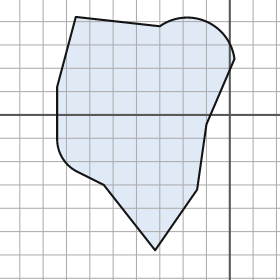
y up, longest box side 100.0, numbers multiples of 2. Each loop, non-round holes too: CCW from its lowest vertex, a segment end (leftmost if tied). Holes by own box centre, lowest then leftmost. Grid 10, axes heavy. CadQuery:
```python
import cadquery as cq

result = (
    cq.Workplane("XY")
    .moveTo(-32.0, -58.0)
    .lineTo(-14.0, -32.0)
    .lineTo(-10.0, -4.0)
    .lineTo(2.0, 24.0)
    .threePointArc((-10.0, 40.0), (-30.0, 38.0))
    .lineTo(-66.0, 42.0)
    .lineTo(-74.0, 12.0)
    .lineTo(-74.0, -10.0)
    .threePointArc((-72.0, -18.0), (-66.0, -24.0))
    .lineTo(-54.0, -30.0)
    .close()
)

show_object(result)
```